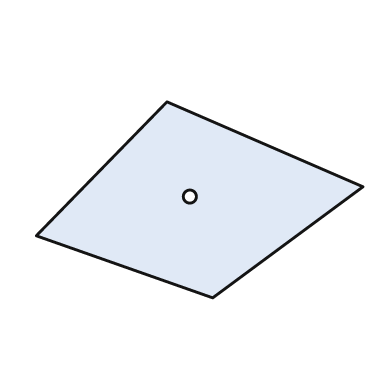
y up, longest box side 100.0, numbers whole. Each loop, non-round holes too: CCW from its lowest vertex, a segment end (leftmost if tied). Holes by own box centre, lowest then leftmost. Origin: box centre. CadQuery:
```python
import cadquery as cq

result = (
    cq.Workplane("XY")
    .moveTo(4.0, -30.0)
    .lineTo(50.0, 4.0)
    .lineTo(-10.0, 30.0)
    .lineTo(-50.0, -11.0)
    .close()
    .moveTo(-3.0, 1.0)
    .circle(2.0)
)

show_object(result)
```